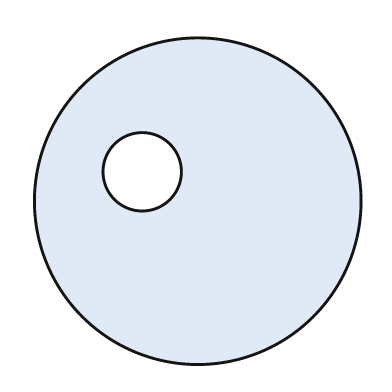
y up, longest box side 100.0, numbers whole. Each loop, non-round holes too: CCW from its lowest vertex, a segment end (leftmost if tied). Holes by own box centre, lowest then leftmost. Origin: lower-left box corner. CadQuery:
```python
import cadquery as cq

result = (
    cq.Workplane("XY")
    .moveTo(50.0, 50.0)
    .circle(50.0)
    .moveTo(33.0, 59.0)
    .circle(12.0)
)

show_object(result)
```